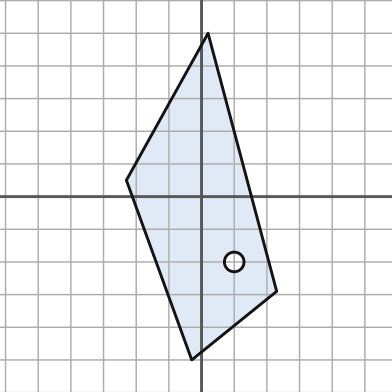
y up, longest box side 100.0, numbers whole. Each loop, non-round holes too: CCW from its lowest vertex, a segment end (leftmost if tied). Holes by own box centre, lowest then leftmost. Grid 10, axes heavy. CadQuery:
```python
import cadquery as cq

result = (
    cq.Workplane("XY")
    .moveTo(-3.0, -50.0)
    .lineTo(23.0, -29.0)
    .lineTo(2.0, 50.0)
    .lineTo(-23.0, 5.0)
    .close()
    .moveTo(10.0, -20.0)
    .circle(3.0)
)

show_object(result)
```